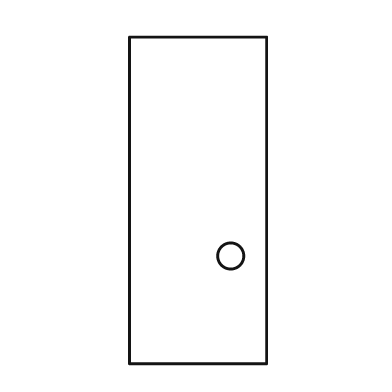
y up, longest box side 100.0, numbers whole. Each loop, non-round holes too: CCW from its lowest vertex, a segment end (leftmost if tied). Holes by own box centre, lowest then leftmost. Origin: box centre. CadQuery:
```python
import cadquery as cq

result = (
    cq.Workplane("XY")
    .moveTo(-21.0, -50.0)
    .lineTo(21.0, -50.0)
    .lineTo(21.0, 50.0)
    .lineTo(-21.0, 50.0)
    .close()
    .moveTo(10.0, -17.0)
    .circle(4.0)
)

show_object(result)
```